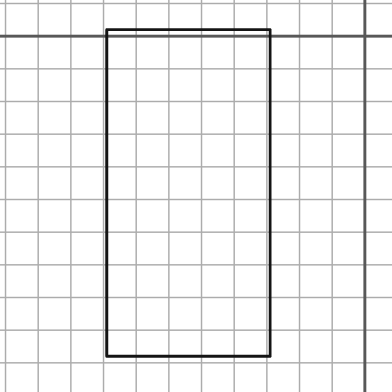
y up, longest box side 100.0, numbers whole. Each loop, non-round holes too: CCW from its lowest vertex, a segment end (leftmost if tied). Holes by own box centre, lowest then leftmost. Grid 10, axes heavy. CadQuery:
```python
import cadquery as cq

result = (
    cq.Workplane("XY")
    .moveTo(-79.0, -98.0)
    .lineTo(-29.0, -98.0)
    .lineTo(-29.0, 2.0)
    .lineTo(-79.0, 2.0)
    .close()
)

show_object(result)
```